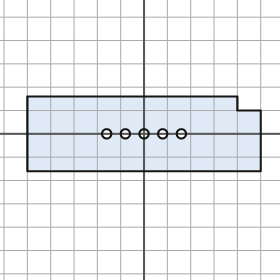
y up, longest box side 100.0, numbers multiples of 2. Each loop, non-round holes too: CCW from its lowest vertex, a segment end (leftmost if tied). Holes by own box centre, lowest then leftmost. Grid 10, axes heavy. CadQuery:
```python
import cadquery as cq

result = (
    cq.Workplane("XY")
    .moveTo(-50.0, -16.0)
    .lineTo(50.0, -16.0)
    .lineTo(50.0, 10.0)
    .lineTo(40.0, 10.0)
    .lineTo(40.0, 16.0)
    .lineTo(-50.0, 16.0)
    .close()
    .moveTo(-16.0, 0.0)
    .circle(2.0)
    .moveTo(-8.0, 0.0)
    .circle(2.0)
    .moveTo(0.0, 0.0)
    .circle(2.0)
    .moveTo(8.0, 0.0)
    .circle(2.0)
    .moveTo(16.0, 0.0)
    .circle(2.0)
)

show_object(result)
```